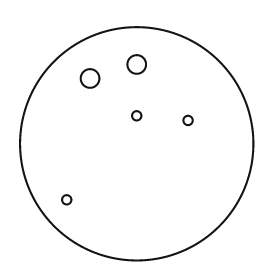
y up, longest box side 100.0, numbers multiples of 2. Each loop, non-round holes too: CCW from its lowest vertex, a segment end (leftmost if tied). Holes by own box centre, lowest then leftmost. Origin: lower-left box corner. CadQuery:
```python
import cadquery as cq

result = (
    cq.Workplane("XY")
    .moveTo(50.0, 50.0)
    .circle(50.0)
    .moveTo(20.0, 26.0)
    .circle(2.0)
    .moveTo(72.0, 60.0)
    .circle(2.0)
    .moveTo(50.0, 62.0)
    .circle(2.0)
    .moveTo(30.0, 78.0)
    .circle(4.0)
    .moveTo(50.0, 84.0)
    .circle(4.0)
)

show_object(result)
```